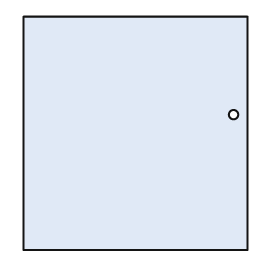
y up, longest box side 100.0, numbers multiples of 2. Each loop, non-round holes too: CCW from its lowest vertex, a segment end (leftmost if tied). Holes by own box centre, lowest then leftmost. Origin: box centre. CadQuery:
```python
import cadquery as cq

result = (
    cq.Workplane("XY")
    .moveTo(-48.0, -50.0)
    .lineTo(48.0, -50.0)
    .lineTo(48.0, 50.0)
    .lineTo(-48.0, 50.0)
    .close()
    .moveTo(42.0, 8.0)
    .circle(2.0)
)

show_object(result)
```